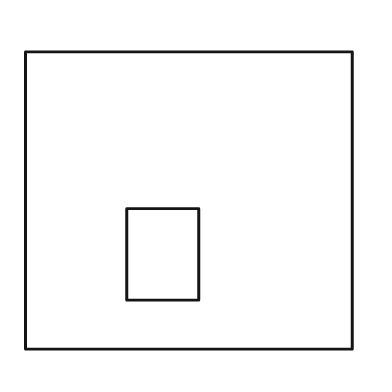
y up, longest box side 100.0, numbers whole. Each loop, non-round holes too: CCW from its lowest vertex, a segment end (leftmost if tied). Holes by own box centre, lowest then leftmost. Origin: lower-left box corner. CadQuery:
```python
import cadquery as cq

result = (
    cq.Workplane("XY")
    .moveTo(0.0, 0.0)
    .lineTo(100.0, 0.0)
    .lineTo(100.0, 91.0)
    .lineTo(0.0, 91.0)
    .close()
    .moveTo(31.0, 15.0)
    .lineTo(53.0, 15.0)
    .lineTo(53.0, 43.0)
    .lineTo(31.0, 43.0)
    .close()
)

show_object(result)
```